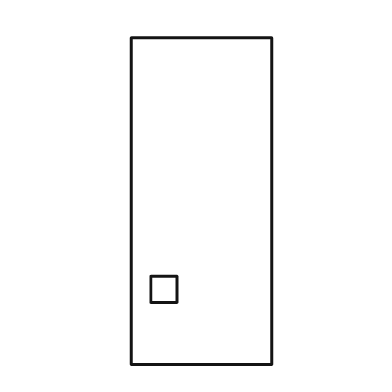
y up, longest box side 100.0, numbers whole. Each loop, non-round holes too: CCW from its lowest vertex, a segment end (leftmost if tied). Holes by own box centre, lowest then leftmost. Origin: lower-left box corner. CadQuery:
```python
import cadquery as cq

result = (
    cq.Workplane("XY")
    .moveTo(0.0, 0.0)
    .lineTo(43.0, 0.0)
    .lineTo(43.0, 100.0)
    .lineTo(0.0, 100.0)
    .close()
    .moveTo(6.0, 19.0)
    .lineTo(14.0, 19.0)
    .lineTo(14.0, 27.0)
    .lineTo(6.0, 27.0)
    .close()
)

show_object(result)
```